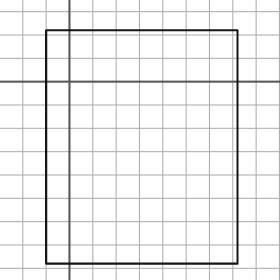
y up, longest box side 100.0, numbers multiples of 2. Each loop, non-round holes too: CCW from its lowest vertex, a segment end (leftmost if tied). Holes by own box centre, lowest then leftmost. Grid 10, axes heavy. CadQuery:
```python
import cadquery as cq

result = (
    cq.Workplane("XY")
    .moveTo(-10.0, -78.0)
    .lineTo(72.0, -78.0)
    .lineTo(72.0, 22.0)
    .lineTo(-10.0, 22.0)
    .close()
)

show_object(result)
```